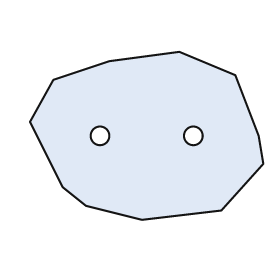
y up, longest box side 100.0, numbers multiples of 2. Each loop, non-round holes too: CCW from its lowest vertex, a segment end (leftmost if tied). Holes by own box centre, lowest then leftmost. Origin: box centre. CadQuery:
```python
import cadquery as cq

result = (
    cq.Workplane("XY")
    .moveTo(-2.0, -36.0)
    .lineTo(32.0, -32.0)
    .lineTo(50.0, -12.0)
    .lineTo(48.0, 0.0)
    .lineTo(38.0, 26.0)
    .lineTo(14.0, 36.0)
    .lineTo(-16.0, 32.0)
    .lineTo(-40.0, 24.0)
    .lineTo(-50.0, 6.0)
    .lineTo(-36.0, -22.0)
    .lineTo(-26.0, -30.0)
    .close()
    .moveTo(-20.0, 0.0)
    .circle(4.0)
    .moveTo(20.0, 0.0)
    .circle(4.0)
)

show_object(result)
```